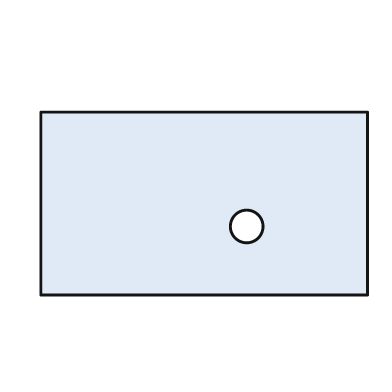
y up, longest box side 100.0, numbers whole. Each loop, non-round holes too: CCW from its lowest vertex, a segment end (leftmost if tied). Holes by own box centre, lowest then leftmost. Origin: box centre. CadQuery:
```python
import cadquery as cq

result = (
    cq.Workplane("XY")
    .moveTo(-50.0, -28.0)
    .lineTo(50.0, -28.0)
    .lineTo(50.0, 28.0)
    .lineTo(-50.0, 28.0)
    .close()
    .moveTo(13.0, -7.0)
    .circle(5.0)
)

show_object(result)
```